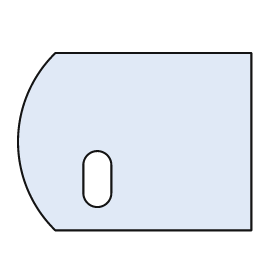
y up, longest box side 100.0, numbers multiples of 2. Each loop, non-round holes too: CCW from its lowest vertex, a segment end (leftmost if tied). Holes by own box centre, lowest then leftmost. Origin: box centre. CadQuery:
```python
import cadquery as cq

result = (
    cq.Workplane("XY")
    .moveTo(-34.0, -38.0)
    .lineTo(50.0, -38.0)
    .lineTo(50.0, 38.0)
    .lineTo(-34.0, 38.0)
    .threePointArc((-50.0, 0.0), (-34.0, -38.0))
    .close()
    .moveTo(-22.0, -22.0)
    .threePointArc((-16.0, -28.0), (-10.0, -22.0))
    .lineTo(-10.0, -10.0)
    .threePointArc((-16.0, -4.0), (-22.0, -10.0))
    .close()
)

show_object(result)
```